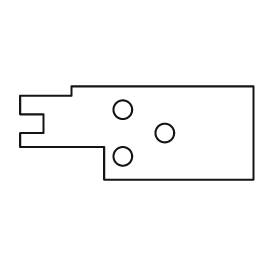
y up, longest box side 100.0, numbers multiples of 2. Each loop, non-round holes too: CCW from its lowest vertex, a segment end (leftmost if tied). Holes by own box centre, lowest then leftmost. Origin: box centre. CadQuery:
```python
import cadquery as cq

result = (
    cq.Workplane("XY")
    .moveTo(-14.0, -20.0)
    .lineTo(50.0, -20.0)
    .lineTo(50.0, 20.0)
    .lineTo(-28.0, 20.0)
    .lineTo(-28.0, 16.0)
    .lineTo(-50.0, 16.0)
    .lineTo(-50.0, 8.0)
    .lineTo(-40.0, 8.0)
    .lineTo(-40.0, 0.0)
    .lineTo(-50.0, 0.0)
    .lineTo(-50.0, -6.0)
    .lineTo(-14.0, -6.0)
    .close()
    .moveTo(-6.0, -10.0)
    .circle(4.0)
    .moveTo(12.0, 0.0)
    .circle(4.0)
    .moveTo(-6.0, 10.0)
    .circle(4.0)
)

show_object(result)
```